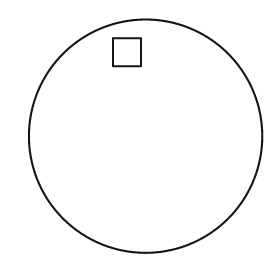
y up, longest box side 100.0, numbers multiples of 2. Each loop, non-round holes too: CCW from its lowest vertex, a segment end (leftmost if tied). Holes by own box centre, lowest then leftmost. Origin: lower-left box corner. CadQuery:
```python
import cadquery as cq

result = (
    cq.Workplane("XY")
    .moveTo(50.0, 50.0)
    .circle(50.0)
    .moveTo(36.0, 80.0)
    .lineTo(48.0, 80.0)
    .lineTo(48.0, 92.0)
    .lineTo(36.0, 92.0)
    .close()
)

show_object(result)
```